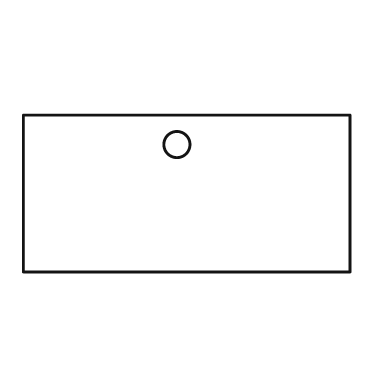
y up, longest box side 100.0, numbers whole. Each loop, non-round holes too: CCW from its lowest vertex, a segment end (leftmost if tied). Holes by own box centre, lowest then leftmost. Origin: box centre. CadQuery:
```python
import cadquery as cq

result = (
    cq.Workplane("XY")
    .moveTo(-50.0, -24.0)
    .lineTo(50.0, -24.0)
    .lineTo(50.0, 24.0)
    .lineTo(-50.0, 24.0)
    .close()
    .moveTo(-3.0, 15.0)
    .circle(4.0)
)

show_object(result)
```